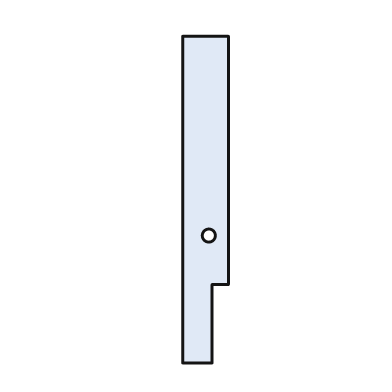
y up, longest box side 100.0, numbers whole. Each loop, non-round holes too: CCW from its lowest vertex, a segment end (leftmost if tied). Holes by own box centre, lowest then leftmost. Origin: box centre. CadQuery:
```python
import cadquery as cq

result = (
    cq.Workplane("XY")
    .moveTo(-7.0, -50.0)
    .lineTo(2.0, -50.0)
    .lineTo(2.0, -26.0)
    .lineTo(7.0, -26.0)
    .lineTo(7.0, 50.0)
    .lineTo(-7.0, 50.0)
    .close()
    .moveTo(1.0, -11.0)
    .circle(2.0)
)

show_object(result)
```